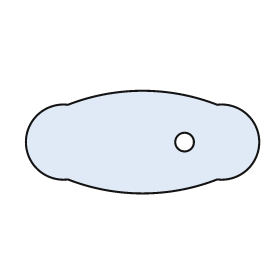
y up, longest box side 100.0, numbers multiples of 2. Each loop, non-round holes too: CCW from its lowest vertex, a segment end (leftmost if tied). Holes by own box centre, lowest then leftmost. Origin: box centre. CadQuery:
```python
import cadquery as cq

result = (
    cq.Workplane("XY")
    .moveTo(-32.0, -16.0)
    .threePointArc((0.0, -22.0), (32.0, -16.0))
    .threePointArc((50.0, 0.0), (32.0, 16.0))
    .threePointArc((0.0, 22.0), (-32.0, 16.0))
    .threePointArc((-50.0, 0.0), (-32.0, -16.0))
    .close()
    .moveTo(18.0, 0.0)
    .circle(4.0)
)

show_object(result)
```